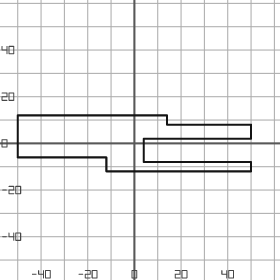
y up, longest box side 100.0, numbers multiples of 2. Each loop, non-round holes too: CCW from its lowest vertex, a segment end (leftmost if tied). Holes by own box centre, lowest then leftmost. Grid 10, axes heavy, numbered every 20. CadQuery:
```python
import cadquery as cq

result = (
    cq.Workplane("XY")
    .moveTo(-12.0, -12.0)
    .lineTo(50.0, -12.0)
    .lineTo(50.0, -8.0)
    .lineTo(4.0, -8.0)
    .lineTo(4.0, 2.0)
    .lineTo(50.0, 2.0)
    .lineTo(50.0, 8.0)
    .lineTo(14.0, 8.0)
    .lineTo(14.0, 12.0)
    .lineTo(-50.0, 12.0)
    .lineTo(-50.0, -6.0)
    .lineTo(-12.0, -6.0)
    .close()
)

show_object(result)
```